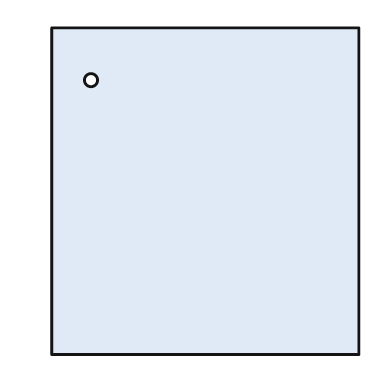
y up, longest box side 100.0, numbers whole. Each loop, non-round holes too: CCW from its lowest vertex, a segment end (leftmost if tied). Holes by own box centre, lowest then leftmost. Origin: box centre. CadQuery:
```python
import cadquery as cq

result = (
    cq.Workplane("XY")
    .moveTo(-47.0, -50.0)
    .lineTo(47.0, -50.0)
    .lineTo(47.0, 50.0)
    .lineTo(-47.0, 50.0)
    .close()
    .moveTo(-35.0, 34.0)
    .circle(2.0)
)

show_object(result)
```